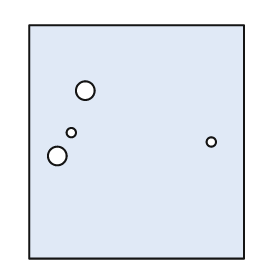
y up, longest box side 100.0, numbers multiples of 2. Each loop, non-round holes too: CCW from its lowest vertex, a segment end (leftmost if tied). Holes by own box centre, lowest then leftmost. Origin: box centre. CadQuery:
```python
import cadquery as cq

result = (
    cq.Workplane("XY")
    .moveTo(-46.0, -50.0)
    .lineTo(46.0, -50.0)
    .lineTo(46.0, 50.0)
    .lineTo(-46.0, 50.0)
    .close()
    .moveTo(-34.0, -6.0)
    .circle(4.0)
    .moveTo(32.0, 0.0)
    .circle(2.0)
    .moveTo(-28.0, 4.0)
    .circle(2.0)
    .moveTo(-22.0, 22.0)
    .circle(4.0)
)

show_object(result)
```